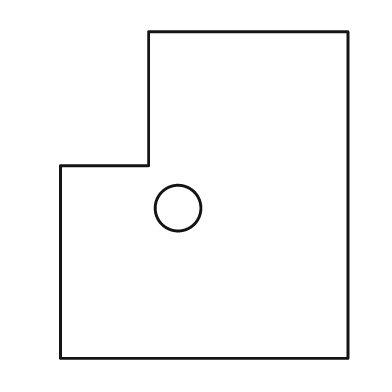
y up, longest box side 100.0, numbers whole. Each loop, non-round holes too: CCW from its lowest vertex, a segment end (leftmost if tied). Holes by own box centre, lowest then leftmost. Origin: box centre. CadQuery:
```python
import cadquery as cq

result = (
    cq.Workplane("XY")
    .moveTo(-44.0, -50.0)
    .lineTo(44.0, -50.0)
    .lineTo(44.0, 50.0)
    .lineTo(-17.0, 50.0)
    .lineTo(-17.0, 9.0)
    .lineTo(-44.0, 9.0)
    .close()
    .moveTo(-8.0, -4.0)
    .circle(7.0)
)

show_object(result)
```